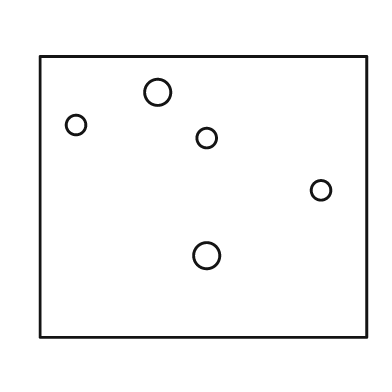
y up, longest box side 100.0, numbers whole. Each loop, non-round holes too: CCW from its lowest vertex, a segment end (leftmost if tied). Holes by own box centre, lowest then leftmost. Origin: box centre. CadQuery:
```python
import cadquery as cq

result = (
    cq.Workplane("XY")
    .moveTo(-50.0, -43.0)
    .lineTo(50.0, -43.0)
    .lineTo(50.0, 43.0)
    .lineTo(-50.0, 43.0)
    .close()
    .moveTo(1.0, -18.0)
    .circle(4.0)
    .moveTo(36.0, 2.0)
    .circle(3.0)
    .moveTo(1.0, 18.0)
    .circle(3.0)
    .moveTo(-39.0, 22.0)
    .circle(3.0)
    .moveTo(-14.0, 32.0)
    .circle(4.0)
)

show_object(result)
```